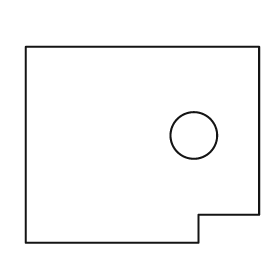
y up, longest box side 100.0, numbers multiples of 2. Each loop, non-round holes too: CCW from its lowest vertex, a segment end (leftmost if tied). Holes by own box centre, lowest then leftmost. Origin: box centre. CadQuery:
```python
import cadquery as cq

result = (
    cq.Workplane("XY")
    .moveTo(-50.0, -42.0)
    .lineTo(24.0, -42.0)
    .lineTo(24.0, -30.0)
    .lineTo(50.0, -30.0)
    .lineTo(50.0, 42.0)
    .lineTo(-50.0, 42.0)
    .close()
    .moveTo(22.0, 4.0)
    .circle(10.0)
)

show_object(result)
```